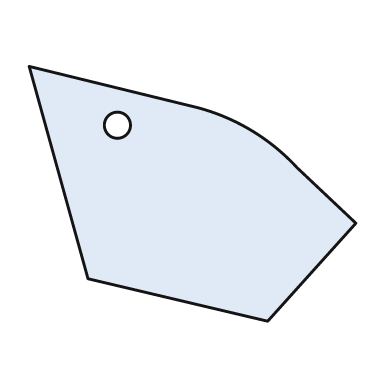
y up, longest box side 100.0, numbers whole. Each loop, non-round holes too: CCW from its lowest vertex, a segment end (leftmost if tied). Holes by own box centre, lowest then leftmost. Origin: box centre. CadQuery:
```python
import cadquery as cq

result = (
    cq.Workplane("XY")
    .moveTo(23.0, -39.0)
    .lineTo(50.0, -9.0)
    .lineTo(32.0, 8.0)
    .threePointArc((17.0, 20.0), (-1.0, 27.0))
    .lineTo(-50.0, 39.0)
    .lineTo(-32.0, -26.0)
    .close()
    .moveTo(-23.0, 21.0)
    .circle(4.0)
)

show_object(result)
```